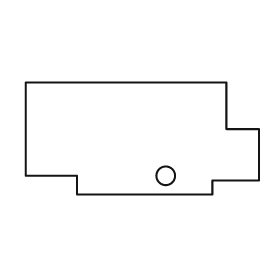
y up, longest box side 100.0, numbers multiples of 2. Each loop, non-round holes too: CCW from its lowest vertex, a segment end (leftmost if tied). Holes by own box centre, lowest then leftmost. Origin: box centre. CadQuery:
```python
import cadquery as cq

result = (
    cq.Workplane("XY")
    .moveTo(-28.0, -24.0)
    .lineTo(30.0, -24.0)
    .lineTo(30.0, -18.0)
    .lineTo(50.0, -18.0)
    .lineTo(50.0, 4.0)
    .lineTo(36.0, 4.0)
    .lineTo(36.0, 24.0)
    .lineTo(-50.0, 24.0)
    .lineTo(-50.0, -16.0)
    .lineTo(-28.0, -16.0)
    .close()
    .moveTo(10.0, -16.0)
    .circle(4.0)
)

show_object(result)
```